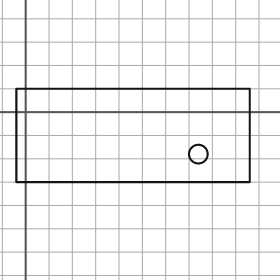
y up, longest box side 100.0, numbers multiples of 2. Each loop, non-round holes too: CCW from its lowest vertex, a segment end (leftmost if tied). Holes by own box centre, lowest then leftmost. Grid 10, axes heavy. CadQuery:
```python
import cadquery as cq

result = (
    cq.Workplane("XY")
    .moveTo(-4.0, -30.0)
    .lineTo(96.0, -30.0)
    .lineTo(96.0, 10.0)
    .lineTo(-4.0, 10.0)
    .close()
    .moveTo(74.0, -18.0)
    .circle(4.0)
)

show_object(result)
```